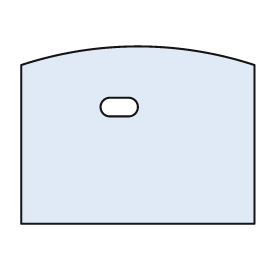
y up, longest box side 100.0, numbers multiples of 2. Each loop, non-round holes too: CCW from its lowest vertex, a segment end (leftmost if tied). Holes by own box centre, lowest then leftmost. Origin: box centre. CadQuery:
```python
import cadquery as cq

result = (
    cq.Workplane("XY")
    .moveTo(-50.0, -38.0)
    .lineTo(50.0, -38.0)
    .lineTo(50.0, 30.0)
    .threePointArc((0.0, 38.0), (-50.0, 30.0))
    .close()
    .moveTo(-12.0, 8.0)
    .lineTo(-4.0, 8.0)
    .threePointArc((0.0, 12.0), (-4.0, 16.0))
    .lineTo(-12.0, 16.0)
    .threePointArc((-16.0, 12.0), (-12.0, 8.0))
    .close()
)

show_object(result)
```